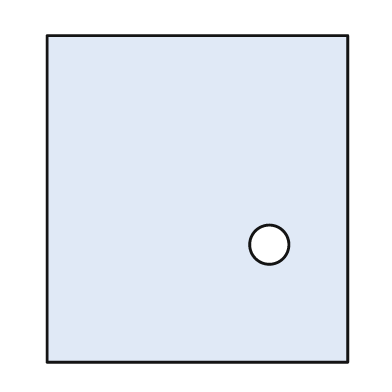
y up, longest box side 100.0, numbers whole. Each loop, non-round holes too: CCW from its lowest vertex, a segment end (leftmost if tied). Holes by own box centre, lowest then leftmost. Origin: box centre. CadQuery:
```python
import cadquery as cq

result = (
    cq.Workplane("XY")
    .moveTo(-46.0, -50.0)
    .lineTo(46.0, -50.0)
    .lineTo(46.0, 50.0)
    .lineTo(-46.0, 50.0)
    .close()
    .moveTo(22.0, -14.0)
    .circle(6.0)
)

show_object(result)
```